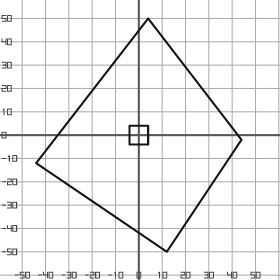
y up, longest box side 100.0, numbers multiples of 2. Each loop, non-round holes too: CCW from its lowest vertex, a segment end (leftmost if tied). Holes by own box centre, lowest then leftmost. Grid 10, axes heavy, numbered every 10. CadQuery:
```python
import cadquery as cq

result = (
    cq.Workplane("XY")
    .moveTo(12.0, -50.0)
    .lineTo(44.0, -2.0)
    .lineTo(4.0, 50.0)
    .lineTo(-44.0, -12.0)
    .close()
    .moveTo(-4.0, -4.0)
    .lineTo(4.0, -4.0)
    .lineTo(4.0, 4.0)
    .lineTo(-4.0, 4.0)
    .close()
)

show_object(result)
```